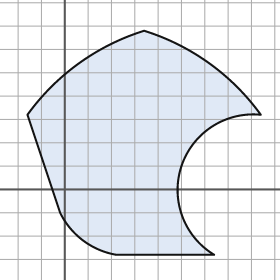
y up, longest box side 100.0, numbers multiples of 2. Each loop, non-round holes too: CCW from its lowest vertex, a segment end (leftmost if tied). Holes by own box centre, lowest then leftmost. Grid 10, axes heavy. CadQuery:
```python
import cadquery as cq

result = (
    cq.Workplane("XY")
    .moveTo(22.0, -28.0)
    .lineTo(64.0, -28.0)
    .threePointArc((50.0, 10.0), (84.0, 32.0))
    .threePointArc((62.0, 54.0), (34.0, 68.0))
    .threePointArc((6.0, 54.0), (-16.0, 32.0))
    .lineTo(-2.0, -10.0)
    .threePointArc((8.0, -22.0), (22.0, -28.0))
    .close()
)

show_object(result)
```